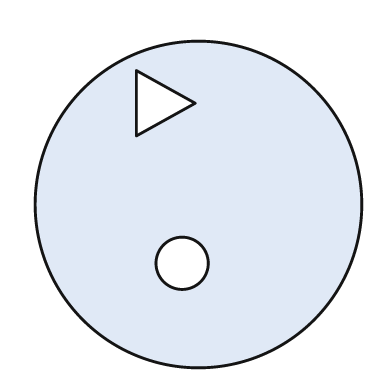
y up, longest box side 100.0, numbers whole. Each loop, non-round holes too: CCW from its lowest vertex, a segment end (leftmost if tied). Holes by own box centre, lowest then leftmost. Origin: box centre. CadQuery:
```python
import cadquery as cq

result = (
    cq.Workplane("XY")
    .moveTo(0.0, 0.0)
    .circle(50.0)
    .moveTo(-5.0, -18.0)
    .circle(8.0)
    .moveTo(-19.0, 21.0)
    .lineTo(-1.0, 31.0)
    .lineTo(-19.0, 41.0)
    .close()
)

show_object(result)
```